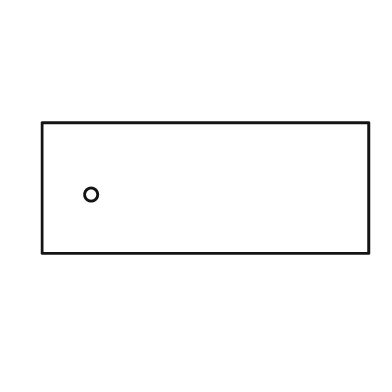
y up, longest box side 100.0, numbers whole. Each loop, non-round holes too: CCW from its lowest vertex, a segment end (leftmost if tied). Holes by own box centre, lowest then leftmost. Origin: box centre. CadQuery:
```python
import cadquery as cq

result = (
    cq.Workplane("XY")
    .moveTo(-50.0, -20.0)
    .lineTo(50.0, -20.0)
    .lineTo(50.0, 20.0)
    .lineTo(-50.0, 20.0)
    .close()
    .moveTo(-35.0, -2.0)
    .circle(2.0)
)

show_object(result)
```